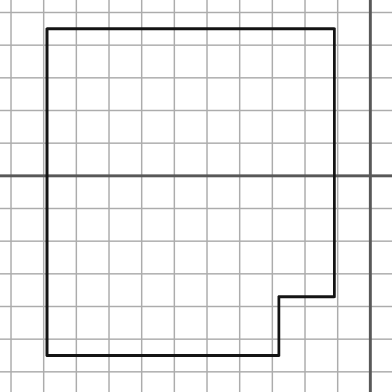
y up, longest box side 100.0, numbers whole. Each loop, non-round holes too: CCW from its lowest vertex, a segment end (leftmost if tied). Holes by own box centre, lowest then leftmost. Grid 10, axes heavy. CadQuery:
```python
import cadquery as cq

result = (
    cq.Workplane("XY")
    .moveTo(-99.0, -55.0)
    .lineTo(-28.0, -55.0)
    .lineTo(-28.0, -37.0)
    .lineTo(-11.0, -37.0)
    .lineTo(-11.0, 45.0)
    .lineTo(-99.0, 45.0)
    .close()
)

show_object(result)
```